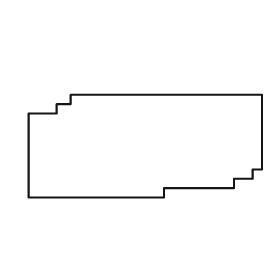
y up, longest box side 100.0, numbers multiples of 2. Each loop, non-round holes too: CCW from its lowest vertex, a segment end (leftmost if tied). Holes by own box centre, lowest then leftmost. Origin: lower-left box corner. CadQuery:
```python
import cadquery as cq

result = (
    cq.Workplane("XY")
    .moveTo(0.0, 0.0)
    .lineTo(58.0, 0.0)
    .lineTo(58.0, 4.0)
    .lineTo(88.0, 4.0)
    .lineTo(88.0, 8.0)
    .lineTo(96.0, 8.0)
    .lineTo(96.0, 12.0)
    .lineTo(100.0, 12.0)
    .lineTo(100.0, 44.0)
    .lineTo(18.0, 44.0)
    .lineTo(18.0, 40.0)
    .lineTo(12.0, 40.0)
    .lineTo(12.0, 36.0)
    .lineTo(0.0, 36.0)
    .close()
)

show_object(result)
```